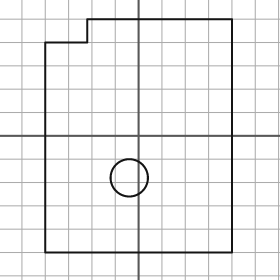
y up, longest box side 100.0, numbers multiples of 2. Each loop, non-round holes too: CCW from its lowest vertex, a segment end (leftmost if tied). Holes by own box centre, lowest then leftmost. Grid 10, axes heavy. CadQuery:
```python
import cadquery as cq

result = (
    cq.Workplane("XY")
    .moveTo(-40.0, -50.0)
    .lineTo(40.0, -50.0)
    .lineTo(40.0, 50.0)
    .lineTo(-22.0, 50.0)
    .lineTo(-22.0, 40.0)
    .lineTo(-40.0, 40.0)
    .close()
    .moveTo(-4.0, -18.0)
    .circle(8.0)
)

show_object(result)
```